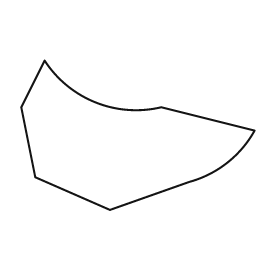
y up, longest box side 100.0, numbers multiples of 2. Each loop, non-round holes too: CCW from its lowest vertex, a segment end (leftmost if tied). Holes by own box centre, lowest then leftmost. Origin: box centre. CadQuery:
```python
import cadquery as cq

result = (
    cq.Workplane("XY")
    .moveTo(-12.0, -32.0)
    .lineTo(22.0, -20.0)
    .threePointArc((38.0, -12.0), (50.0, 2.0))
    .lineTo(10.0, 12.0)
    .threePointArc((-18.0, 14.0), (-40.0, 32.0))
    .lineTo(-50.0, 12.0)
    .lineTo(-44.0, -18.0)
    .close()
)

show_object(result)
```